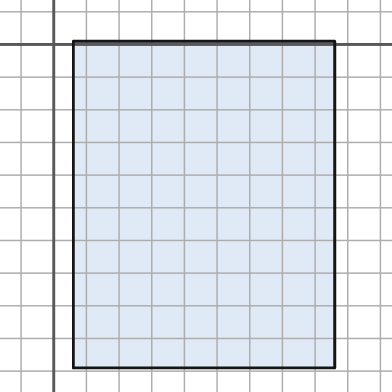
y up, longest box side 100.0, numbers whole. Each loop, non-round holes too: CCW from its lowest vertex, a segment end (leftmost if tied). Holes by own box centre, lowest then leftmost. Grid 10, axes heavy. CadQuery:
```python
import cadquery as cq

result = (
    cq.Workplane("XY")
    .moveTo(6.0, -99.0)
    .lineTo(86.0, -99.0)
    .lineTo(86.0, 1.0)
    .lineTo(6.0, 1.0)
    .close()
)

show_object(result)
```